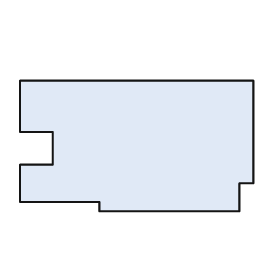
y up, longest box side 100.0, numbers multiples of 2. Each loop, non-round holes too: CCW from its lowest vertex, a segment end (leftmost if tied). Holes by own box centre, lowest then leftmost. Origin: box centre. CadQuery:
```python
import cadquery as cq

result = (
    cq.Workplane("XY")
    .moveTo(-16.0, -28.0)
    .lineTo(44.0, -28.0)
    .lineTo(44.0, -16.0)
    .lineTo(50.0, -16.0)
    .lineTo(50.0, 28.0)
    .lineTo(-50.0, 28.0)
    .lineTo(-50.0, 6.0)
    .lineTo(-36.0, 6.0)
    .lineTo(-36.0, -8.0)
    .lineTo(-50.0, -8.0)
    .lineTo(-50.0, -24.0)
    .lineTo(-16.0, -24.0)
    .close()
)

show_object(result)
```